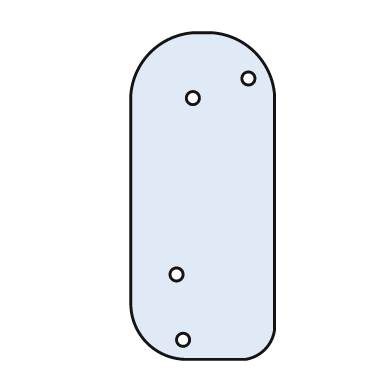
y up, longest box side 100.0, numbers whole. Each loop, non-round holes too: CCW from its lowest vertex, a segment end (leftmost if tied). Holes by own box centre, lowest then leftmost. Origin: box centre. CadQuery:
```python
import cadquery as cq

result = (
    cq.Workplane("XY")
    .moveTo(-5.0, -50.0)
    .lineTo(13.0, -50.0)
    .threePointArc((19.0, -47.0), (22.0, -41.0))
    .lineTo(22.0, 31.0)
    .threePointArc((16.0, 44.0), (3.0, 50.0))
    .lineTo(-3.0, 50.0)
    .threePointArc((-16.0, 44.0), (-22.0, 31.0))
    .lineTo(-22.0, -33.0)
    .threePointArc((-17.0, -45.0), (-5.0, -50.0))
    .close()
    .moveTo(-6.0, -44.0)
    .circle(2.0)
    .moveTo(-8.0, -24.0)
    .circle(2.0)
    .moveTo(-3.0, 30.0)
    .circle(2.0)
    .moveTo(14.0, 36.0)
    .circle(2.0)
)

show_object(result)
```